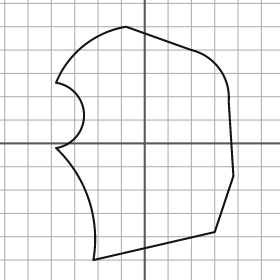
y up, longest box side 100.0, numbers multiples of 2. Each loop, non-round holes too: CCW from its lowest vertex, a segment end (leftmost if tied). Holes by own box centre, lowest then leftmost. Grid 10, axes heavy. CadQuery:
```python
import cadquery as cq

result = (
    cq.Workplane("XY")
    .moveTo(-22.0, -50.0)
    .lineTo(30.0, -38.0)
    .lineTo(38.0, -14.0)
    .lineTo(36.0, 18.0)
    .threePointArc((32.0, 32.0), (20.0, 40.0))
    .lineTo(-8.0, 50.0)
    .threePointArc((-26.0, 42.0), (-38.0, 26.0))
    .threePointArc((-26.0, 12.0), (-38.0, -2.0))
    .threePointArc((-24.0, -24.0), (-22.0, -50.0))
    .close()
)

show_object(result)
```